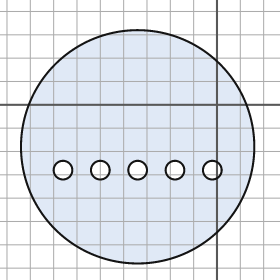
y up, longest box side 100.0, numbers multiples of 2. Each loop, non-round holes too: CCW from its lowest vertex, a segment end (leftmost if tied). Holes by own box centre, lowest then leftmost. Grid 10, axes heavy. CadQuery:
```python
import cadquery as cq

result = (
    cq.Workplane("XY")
    .moveTo(-34.0, -18.0)
    .circle(50.0)
    .moveTo(-66.0, -28.0)
    .circle(4.0)
    .moveTo(-50.0, -28.0)
    .circle(4.0)
    .moveTo(-34.0, -28.0)
    .circle(4.0)
    .moveTo(-18.0, -28.0)
    .circle(4.0)
    .moveTo(-2.0, -28.0)
    .circle(4.0)
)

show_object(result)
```